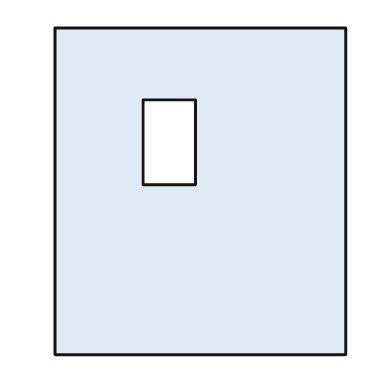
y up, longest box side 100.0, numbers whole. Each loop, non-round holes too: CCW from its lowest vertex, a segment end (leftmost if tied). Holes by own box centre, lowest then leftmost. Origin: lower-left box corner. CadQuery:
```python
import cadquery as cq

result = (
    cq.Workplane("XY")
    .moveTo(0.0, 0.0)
    .lineTo(89.0, 0.0)
    .lineTo(89.0, 100.0)
    .lineTo(0.0, 100.0)
    .close()
    .moveTo(27.0, 52.0)
    .lineTo(43.0, 52.0)
    .lineTo(43.0, 78.0)
    .lineTo(27.0, 78.0)
    .close()
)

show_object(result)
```